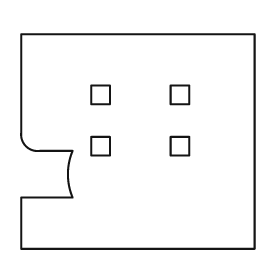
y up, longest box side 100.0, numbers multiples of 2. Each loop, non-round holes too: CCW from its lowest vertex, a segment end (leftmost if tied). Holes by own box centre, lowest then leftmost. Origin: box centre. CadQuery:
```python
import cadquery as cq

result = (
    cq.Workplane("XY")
    .moveTo(-50.0, -46.0)
    .lineTo(50.0, -46.0)
    .lineTo(50.0, 46.0)
    .lineTo(-50.0, 46.0)
    .lineTo(-50.0, 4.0)
    .threePointArc((-48.0, -2.0), (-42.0, -4.0))
    .lineTo(-28.0, -4.0)
    .threePointArc((-30.0, -14.0), (-28.0, -24.0))
    .lineTo(-50.0, -24.0)
    .close()
    .moveTo(-20.0, -6.0)
    .lineTo(-12.0, -6.0)
    .lineTo(-12.0, 2.0)
    .lineTo(-20.0, 2.0)
    .close()
    .moveTo(14.0, -6.0)
    .lineTo(22.0, -6.0)
    .lineTo(22.0, 2.0)
    .lineTo(14.0, 2.0)
    .close()
    .moveTo(-20.0, 16.0)
    .lineTo(-12.0, 16.0)
    .lineTo(-12.0, 24.0)
    .lineTo(-20.0, 24.0)
    .close()
    .moveTo(14.0, 16.0)
    .lineTo(22.0, 16.0)
    .lineTo(22.0, 24.0)
    .lineTo(14.0, 24.0)
    .close()
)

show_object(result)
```